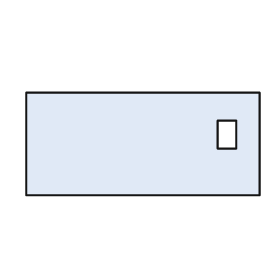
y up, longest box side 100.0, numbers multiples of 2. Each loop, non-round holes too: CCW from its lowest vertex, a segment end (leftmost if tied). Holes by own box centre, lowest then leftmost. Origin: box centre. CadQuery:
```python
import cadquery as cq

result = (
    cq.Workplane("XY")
    .moveTo(-50.0, -22.0)
    .lineTo(50.0, -22.0)
    .lineTo(50.0, 22.0)
    .lineTo(-50.0, 22.0)
    .close()
    .moveTo(32.0, -2.0)
    .lineTo(40.0, -2.0)
    .lineTo(40.0, 10.0)
    .lineTo(32.0, 10.0)
    .close()
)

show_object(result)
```